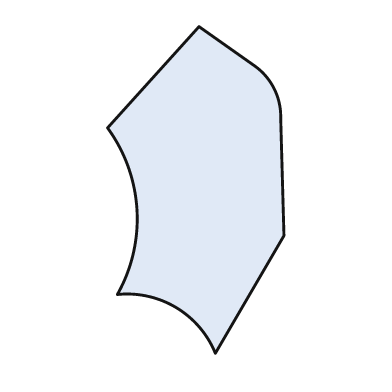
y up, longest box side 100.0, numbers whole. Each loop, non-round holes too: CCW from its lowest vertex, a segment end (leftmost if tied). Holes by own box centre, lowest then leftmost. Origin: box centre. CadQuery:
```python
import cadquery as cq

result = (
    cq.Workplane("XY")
    .moveTo(6.0, -50.0)
    .lineTo(27.0, -14.0)
    .lineTo(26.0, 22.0)
    .threePointArc((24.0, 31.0), (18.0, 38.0))
    .lineTo(1.0, 50.0)
    .lineTo(-27.0, 19.0)
    .threePointArc((-18.0, -6.0), (-24.0, -32.0))
    .threePointArc((-6.0, -36.0), (6.0, -50.0))
    .close()
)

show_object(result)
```